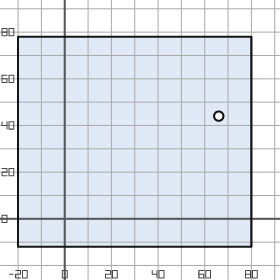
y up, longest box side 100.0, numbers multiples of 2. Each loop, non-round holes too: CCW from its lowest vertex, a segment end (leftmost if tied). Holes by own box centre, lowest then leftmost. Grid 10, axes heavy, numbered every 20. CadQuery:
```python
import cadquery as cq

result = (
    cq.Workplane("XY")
    .moveTo(-20.0, -12.0)
    .lineTo(80.0, -12.0)
    .lineTo(80.0, 78.0)
    .lineTo(-20.0, 78.0)
    .close()
    .moveTo(66.0, 44.0)
    .circle(2.0)
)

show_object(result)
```